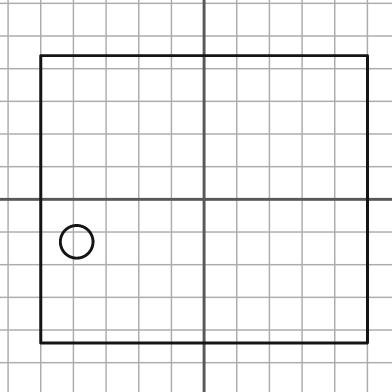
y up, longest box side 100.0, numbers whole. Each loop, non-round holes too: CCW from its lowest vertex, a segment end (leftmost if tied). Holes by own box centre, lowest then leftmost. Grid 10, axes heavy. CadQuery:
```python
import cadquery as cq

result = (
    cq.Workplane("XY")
    .moveTo(-50.0, -44.0)
    .lineTo(50.0, -44.0)
    .lineTo(50.0, 44.0)
    .lineTo(-50.0, 44.0)
    .close()
    .moveTo(-39.0, -13.0)
    .circle(5.0)
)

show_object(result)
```